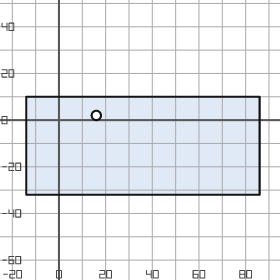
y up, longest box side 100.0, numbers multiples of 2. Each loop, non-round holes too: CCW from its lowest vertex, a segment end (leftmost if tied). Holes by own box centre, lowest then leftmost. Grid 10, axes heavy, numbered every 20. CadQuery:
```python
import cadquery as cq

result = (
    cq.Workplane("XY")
    .moveTo(-14.0, -32.0)
    .lineTo(86.0, -32.0)
    .lineTo(86.0, 10.0)
    .lineTo(-14.0, 10.0)
    .close()
    .moveTo(16.0, 2.0)
    .circle(2.0)
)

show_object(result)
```